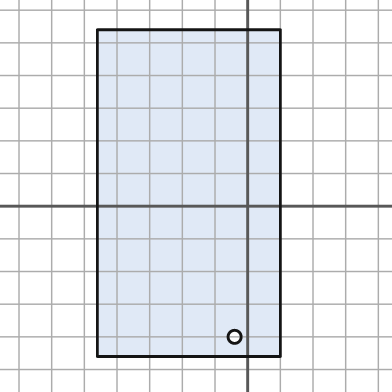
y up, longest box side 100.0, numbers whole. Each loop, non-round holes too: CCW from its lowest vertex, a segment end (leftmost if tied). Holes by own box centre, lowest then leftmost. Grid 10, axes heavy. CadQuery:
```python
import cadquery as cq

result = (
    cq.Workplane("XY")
    .moveTo(-46.0, -46.0)
    .lineTo(10.0, -46.0)
    .lineTo(10.0, 54.0)
    .lineTo(-46.0, 54.0)
    .close()
    .moveTo(-4.0, -40.0)
    .circle(2.0)
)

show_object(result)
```